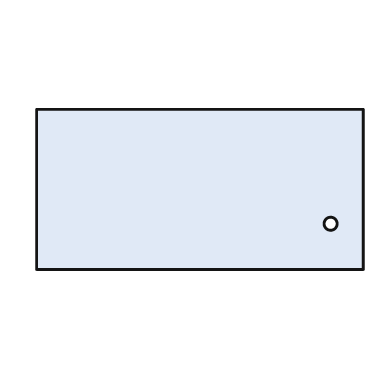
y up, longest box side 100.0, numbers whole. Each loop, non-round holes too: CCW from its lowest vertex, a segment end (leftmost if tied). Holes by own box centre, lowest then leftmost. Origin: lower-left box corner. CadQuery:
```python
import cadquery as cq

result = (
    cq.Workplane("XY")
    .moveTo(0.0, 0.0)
    .lineTo(100.0, 0.0)
    .lineTo(100.0, 49.0)
    .lineTo(0.0, 49.0)
    .close()
    .moveTo(90.0, 14.0)
    .circle(2.0)
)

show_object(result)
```